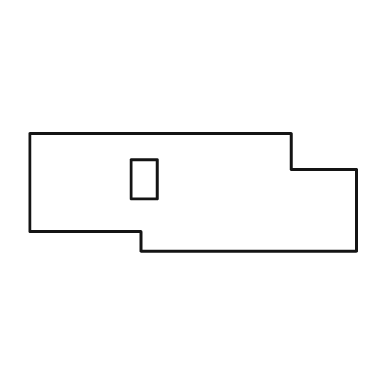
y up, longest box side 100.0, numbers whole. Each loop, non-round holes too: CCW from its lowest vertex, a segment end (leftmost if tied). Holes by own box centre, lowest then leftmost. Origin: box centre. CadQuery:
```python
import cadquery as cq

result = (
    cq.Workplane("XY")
    .moveTo(-16.0, -18.0)
    .lineTo(50.0, -18.0)
    .lineTo(50.0, 7.0)
    .lineTo(30.0, 7.0)
    .lineTo(30.0, 18.0)
    .lineTo(-50.0, 18.0)
    .lineTo(-50.0, -12.0)
    .lineTo(-16.0, -12.0)
    .close()
    .moveTo(-19.0, -2.0)
    .lineTo(-11.0, -2.0)
    .lineTo(-11.0, 10.0)
    .lineTo(-19.0, 10.0)
    .close()
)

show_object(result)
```